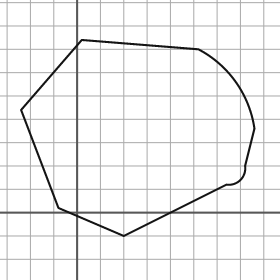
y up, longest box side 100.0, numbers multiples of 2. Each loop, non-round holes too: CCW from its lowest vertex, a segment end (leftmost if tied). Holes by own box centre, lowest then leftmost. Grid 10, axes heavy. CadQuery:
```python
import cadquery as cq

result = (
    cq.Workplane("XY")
    .moveTo(20.0, -10.0)
    .lineTo(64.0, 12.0)
    .threePointArc((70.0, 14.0), (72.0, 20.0))
    .lineTo(76.0, 36.0)
    .threePointArc((68.0, 56.0), (52.0, 70.0))
    .lineTo(2.0, 74.0)
    .lineTo(-24.0, 44.0)
    .lineTo(-8.0, 2.0)
    .close()
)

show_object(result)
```